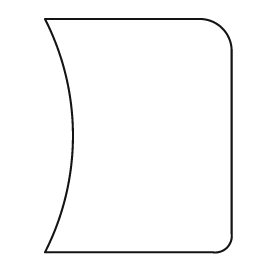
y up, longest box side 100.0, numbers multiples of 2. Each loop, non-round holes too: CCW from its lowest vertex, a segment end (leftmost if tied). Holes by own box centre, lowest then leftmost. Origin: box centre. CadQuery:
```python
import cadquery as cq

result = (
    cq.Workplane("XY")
    .moveTo(-40.0, -50.0)
    .lineTo(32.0, -50.0)
    .threePointArc((38.0, -48.0), (40.0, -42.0))
    .lineTo(40.0, 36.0)
    .threePointArc((36.0, 46.0), (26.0, 50.0))
    .lineTo(-40.0, 50.0)
    .threePointArc((-28.0, 0.0), (-40.0, -50.0))
    .close()
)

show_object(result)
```